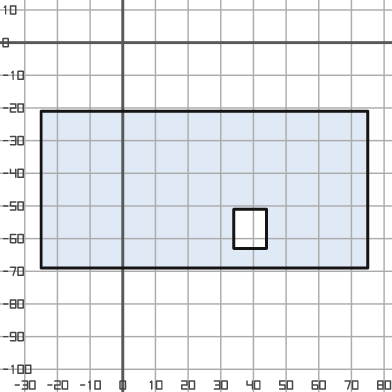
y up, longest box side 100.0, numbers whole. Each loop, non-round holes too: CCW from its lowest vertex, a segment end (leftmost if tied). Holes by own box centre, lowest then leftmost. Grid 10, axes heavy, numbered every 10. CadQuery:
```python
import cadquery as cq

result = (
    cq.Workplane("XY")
    .moveTo(-25.0, -69.0)
    .lineTo(75.0, -69.0)
    .lineTo(75.0, -21.0)
    .lineTo(-25.0, -21.0)
    .close()
    .moveTo(34.0, -63.0)
    .lineTo(44.0, -63.0)
    .lineTo(44.0, -51.0)
    .lineTo(34.0, -51.0)
    .close()
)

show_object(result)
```